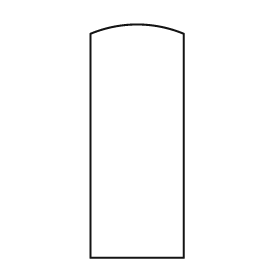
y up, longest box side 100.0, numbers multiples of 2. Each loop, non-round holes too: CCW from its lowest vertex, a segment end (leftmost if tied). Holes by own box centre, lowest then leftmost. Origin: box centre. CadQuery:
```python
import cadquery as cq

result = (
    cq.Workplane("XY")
    .moveTo(-20.0, -50.0)
    .lineTo(20.0, -50.0)
    .lineTo(20.0, 46.0)
    .threePointArc((0.0, 50.0), (-20.0, 46.0))
    .close()
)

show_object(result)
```